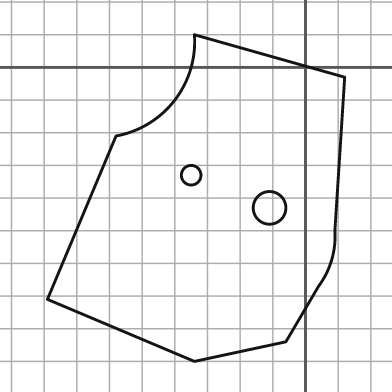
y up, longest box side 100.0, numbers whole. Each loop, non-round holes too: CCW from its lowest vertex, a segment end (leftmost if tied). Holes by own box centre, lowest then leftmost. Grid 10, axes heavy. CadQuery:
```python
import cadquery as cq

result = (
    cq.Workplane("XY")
    .moveTo(-34.0, -90.0)
    .lineTo(-6.0, -84.0)
    .lineTo(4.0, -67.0)
    .threePointArc((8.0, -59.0), (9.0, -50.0))
    .lineTo(12.0, -3.0)
    .lineTo(-34.0, 10.0)
    .threePointArc((-40.0, -10.0), (-58.0, -21.0))
    .lineTo(-79.0, -71.0)
    .close()
    .moveTo(-11.0, -43.0)
    .circle(5.0)
    .moveTo(-35.0, -33.0)
    .circle(3.0)
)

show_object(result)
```